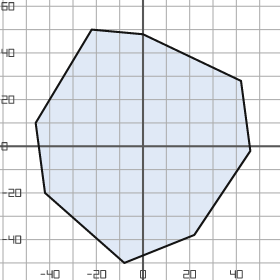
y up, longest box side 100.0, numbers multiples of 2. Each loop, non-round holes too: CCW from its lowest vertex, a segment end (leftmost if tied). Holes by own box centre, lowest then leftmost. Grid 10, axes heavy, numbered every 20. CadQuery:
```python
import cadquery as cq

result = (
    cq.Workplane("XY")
    .moveTo(-8.0, -50.0)
    .lineTo(22.0, -38.0)
    .lineTo(46.0, -2.0)
    .lineTo(42.0, 28.0)
    .lineTo(0.0, 48.0)
    .lineTo(-22.0, 50.0)
    .lineTo(-46.0, 10.0)
    .lineTo(-42.0, -20.0)
    .close()
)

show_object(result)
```